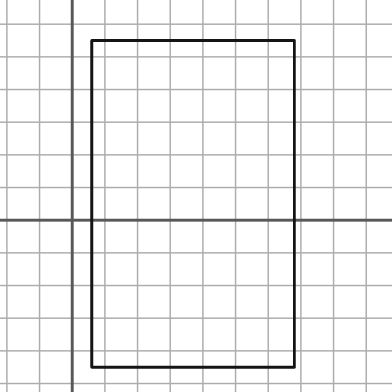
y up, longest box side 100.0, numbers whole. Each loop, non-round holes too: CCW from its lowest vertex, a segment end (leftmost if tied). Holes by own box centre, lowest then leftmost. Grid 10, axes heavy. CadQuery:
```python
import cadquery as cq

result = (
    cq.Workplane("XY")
    .moveTo(6.0, -45.0)
    .lineTo(68.0, -45.0)
    .lineTo(68.0, 55.0)
    .lineTo(6.0, 55.0)
    .close()
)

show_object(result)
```